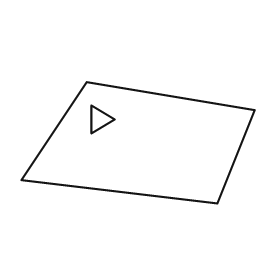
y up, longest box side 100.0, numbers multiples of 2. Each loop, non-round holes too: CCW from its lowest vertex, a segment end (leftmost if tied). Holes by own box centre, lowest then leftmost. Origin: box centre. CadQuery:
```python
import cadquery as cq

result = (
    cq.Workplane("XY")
    .moveTo(34.0, -26.0)
    .lineTo(50.0, 14.0)
    .lineTo(-22.0, 26.0)
    .lineTo(-50.0, -16.0)
    .close()
    .moveTo(-20.0, 4.0)
    .lineTo(-10.0, 10.0)
    .lineTo(-20.0, 16.0)
    .close()
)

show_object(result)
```